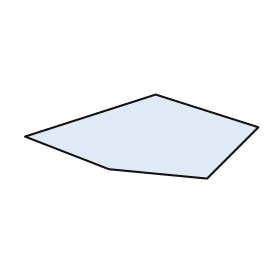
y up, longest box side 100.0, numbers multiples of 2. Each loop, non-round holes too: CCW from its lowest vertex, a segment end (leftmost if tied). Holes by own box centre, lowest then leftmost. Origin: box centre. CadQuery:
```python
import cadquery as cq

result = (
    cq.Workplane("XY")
    .moveTo(28.0, -18.0)
    .lineTo(50.0, 4.0)
    .lineTo(6.0, 18.0)
    .lineTo(-50.0, 0.0)
    .lineTo(-14.0, -14.0)
    .close()
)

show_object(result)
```